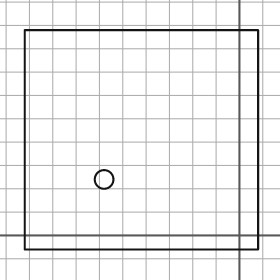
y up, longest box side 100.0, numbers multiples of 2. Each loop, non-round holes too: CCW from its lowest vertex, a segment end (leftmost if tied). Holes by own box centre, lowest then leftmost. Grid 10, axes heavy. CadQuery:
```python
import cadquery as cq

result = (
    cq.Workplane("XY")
    .moveTo(-92.0, -6.0)
    .lineTo(8.0, -6.0)
    .lineTo(8.0, 88.0)
    .lineTo(-92.0, 88.0)
    .close()
    .moveTo(-58.0, 24.0)
    .circle(4.0)
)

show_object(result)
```